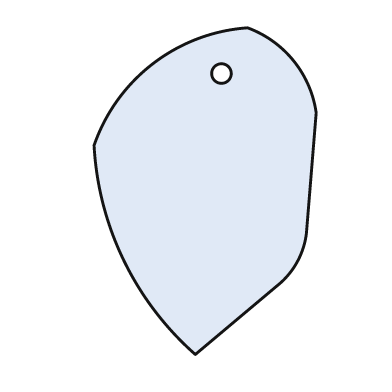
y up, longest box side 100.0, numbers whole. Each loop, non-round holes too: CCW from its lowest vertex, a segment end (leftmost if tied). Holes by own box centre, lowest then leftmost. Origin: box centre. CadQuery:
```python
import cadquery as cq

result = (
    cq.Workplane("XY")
    .moveTo(-3.0, -50.0)
    .lineTo(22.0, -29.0)
    .threePointArc((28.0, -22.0), (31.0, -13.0))
    .lineTo(34.0, 24.0)
    .threePointArc((27.0, 40.0), (13.0, 50.0))
    .threePointArc((-16.0, 39.0), (-34.0, 14.0))
    .threePointArc((-25.0, -21.0), (-3.0, -50.0))
    .close()
    .moveTo(5.0, 36.0)
    .circle(3.0)
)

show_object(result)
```